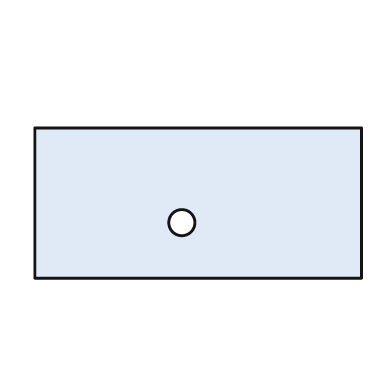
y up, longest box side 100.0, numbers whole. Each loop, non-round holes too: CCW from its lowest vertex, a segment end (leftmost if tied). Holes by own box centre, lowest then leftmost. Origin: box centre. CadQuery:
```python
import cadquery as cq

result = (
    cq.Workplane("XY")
    .moveTo(-50.0, -23.0)
    .lineTo(50.0, -23.0)
    .lineTo(50.0, 23.0)
    .lineTo(-50.0, 23.0)
    .close()
    .moveTo(-5.0, -6.0)
    .circle(4.0)
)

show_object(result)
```